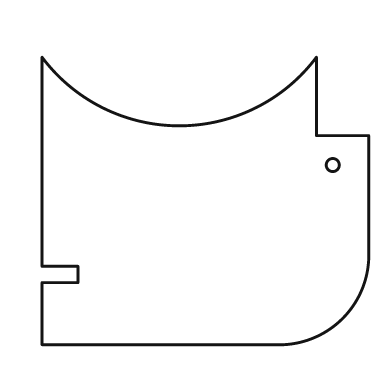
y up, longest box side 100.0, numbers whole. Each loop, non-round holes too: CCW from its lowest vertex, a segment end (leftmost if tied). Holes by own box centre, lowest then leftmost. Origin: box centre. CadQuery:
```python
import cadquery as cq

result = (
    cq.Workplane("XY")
    .moveTo(-50.0, -44.0)
    .lineTo(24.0, -44.0)
    .threePointArc((42.0, -36.0), (50.0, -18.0))
    .lineTo(50.0, 20.0)
    .lineTo(34.0, 20.0)
    .lineTo(34.0, 44.0)
    .threePointArc((-8.0, 23.0), (-50.0, 44.0))
    .lineTo(-50.0, -20.0)
    .lineTo(-39.0, -20.0)
    .lineTo(-39.0, -25.0)
    .lineTo(-50.0, -25.0)
    .close()
    .moveTo(39.0, 11.0)
    .circle(2.0)
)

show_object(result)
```